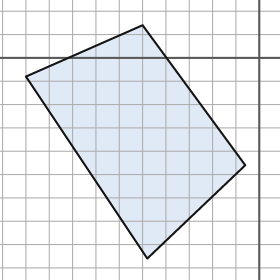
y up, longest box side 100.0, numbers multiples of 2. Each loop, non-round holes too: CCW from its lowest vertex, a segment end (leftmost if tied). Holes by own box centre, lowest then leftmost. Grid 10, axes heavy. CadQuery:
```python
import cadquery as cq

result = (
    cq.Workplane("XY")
    .moveTo(-48.0, -86.0)
    .lineTo(-6.0, -46.0)
    .lineTo(-50.0, 14.0)
    .lineTo(-100.0, -8.0)
    .close()
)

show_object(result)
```